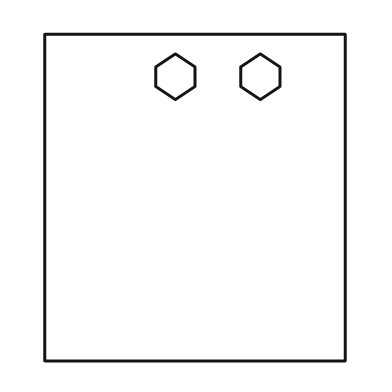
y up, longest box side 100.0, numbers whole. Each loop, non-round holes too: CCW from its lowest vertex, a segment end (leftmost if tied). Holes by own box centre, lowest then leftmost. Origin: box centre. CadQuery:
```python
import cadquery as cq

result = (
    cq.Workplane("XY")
    .moveTo(-46.0, -50.0)
    .lineTo(46.0, -50.0)
    .lineTo(46.0, 50.0)
    .lineTo(-46.0, 50.0)
    .close()
    .moveTo(-6.0, 30.0)
    .lineTo(0.0, 34.0)
    .lineTo(0.0, 40.0)
    .lineTo(-6.0, 44.0)
    .lineTo(-12.0, 40.0)
    .lineTo(-12.0, 34.0)
    .close()
    .moveTo(20.0, 30.0)
    .lineTo(26.0, 34.0)
    .lineTo(26.0, 40.0)
    .lineTo(20.0, 44.0)
    .lineTo(14.0, 40.0)
    .lineTo(14.0, 34.0)
    .close()
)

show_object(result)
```